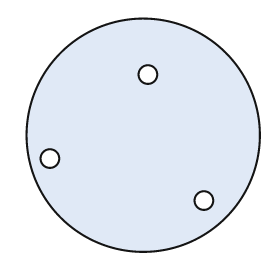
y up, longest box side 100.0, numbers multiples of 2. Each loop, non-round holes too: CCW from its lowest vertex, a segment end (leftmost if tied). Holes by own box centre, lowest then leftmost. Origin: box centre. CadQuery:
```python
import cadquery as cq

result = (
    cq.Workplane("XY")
    .moveTo(0.0, 0.0)
    .circle(50.0)
    .moveTo(26.0, -28.0)
    .circle(4.0)
    .moveTo(-40.0, -10.0)
    .circle(4.0)
    .moveTo(2.0, 26.0)
    .circle(4.0)
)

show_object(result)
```